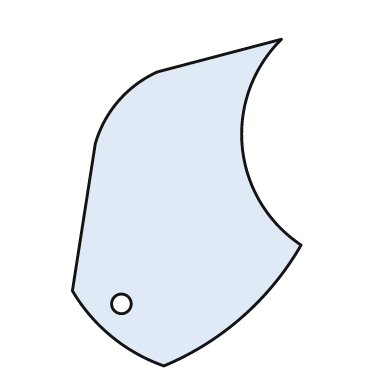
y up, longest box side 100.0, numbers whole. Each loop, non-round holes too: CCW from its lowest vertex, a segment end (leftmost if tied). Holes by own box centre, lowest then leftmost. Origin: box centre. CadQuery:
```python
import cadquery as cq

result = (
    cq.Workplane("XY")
    .moveTo(-7.0, -50.0)
    .threePointArc((17.0, -35.0), (35.0, -13.0))
    .threePointArc((17.0, 17.0), (29.0, 50.0))
    .lineTo(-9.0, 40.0)
    .threePointArc((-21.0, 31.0), (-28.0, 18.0))
    .lineTo(-35.0, -27.0)
    .threePointArc((-23.0, -41.0), (-7.0, -50.0))
    .close()
    .moveTo(-20.0, -31.0)
    .circle(3.0)
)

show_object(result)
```